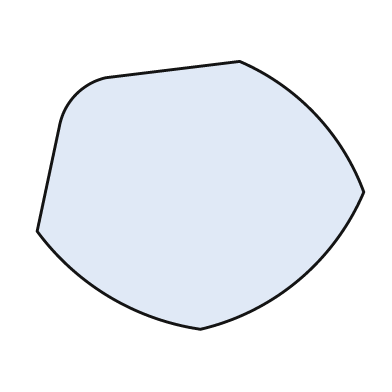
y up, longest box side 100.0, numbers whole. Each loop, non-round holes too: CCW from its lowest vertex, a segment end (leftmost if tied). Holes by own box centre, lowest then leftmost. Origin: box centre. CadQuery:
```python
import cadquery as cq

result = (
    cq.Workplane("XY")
    .moveTo(0.0, -41.0)
    .threePointArc((30.0, -26.0), (50.0, 1.0))
    .threePointArc((35.0, 25.0), (12.0, 41.0))
    .lineTo(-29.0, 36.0)
    .threePointArc((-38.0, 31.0), (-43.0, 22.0))
    .lineTo(-50.0, -11.0)
    .threePointArc((-28.0, -31.0), (0.0, -41.0))
    .close()
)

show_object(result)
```